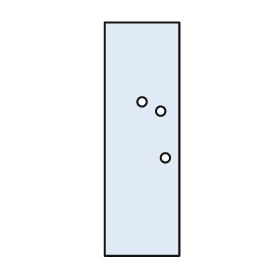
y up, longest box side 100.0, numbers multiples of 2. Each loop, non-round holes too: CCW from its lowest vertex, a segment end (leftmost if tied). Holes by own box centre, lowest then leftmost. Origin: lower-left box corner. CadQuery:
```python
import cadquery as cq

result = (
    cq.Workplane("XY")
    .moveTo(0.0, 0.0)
    .lineTo(32.0, 0.0)
    .lineTo(32.0, 100.0)
    .lineTo(0.0, 100.0)
    .close()
    .moveTo(26.0, 42.0)
    .circle(2.0)
    .moveTo(24.0, 62.0)
    .circle(2.0)
    .moveTo(16.0, 66.0)
    .circle(2.0)
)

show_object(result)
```